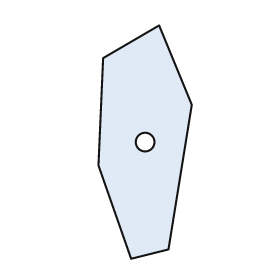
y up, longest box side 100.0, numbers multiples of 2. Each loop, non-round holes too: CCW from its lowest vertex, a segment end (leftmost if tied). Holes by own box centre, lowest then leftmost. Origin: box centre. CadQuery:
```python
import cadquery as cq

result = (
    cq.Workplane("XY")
    .moveTo(-6.0, -50.0)
    .lineTo(10.0, -46.0)
    .lineTo(20.0, 16.0)
    .lineTo(6.0, 50.0)
    .lineTo(-18.0, 36.0)
    .lineTo(-20.0, -10.0)
    .close()
    .moveTo(0.0, 0.0)
    .circle(4.0)
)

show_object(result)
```